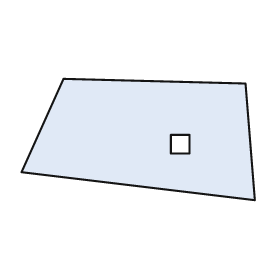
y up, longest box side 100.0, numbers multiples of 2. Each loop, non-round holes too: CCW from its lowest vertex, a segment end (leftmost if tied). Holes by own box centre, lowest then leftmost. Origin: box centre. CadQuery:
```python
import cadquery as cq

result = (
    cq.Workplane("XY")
    .moveTo(50.0, -26.0)
    .lineTo(46.0, 24.0)
    .lineTo(-32.0, 26.0)
    .lineTo(-50.0, -14.0)
    .close()
    .moveTo(14.0, -6.0)
    .lineTo(22.0, -6.0)
    .lineTo(22.0, 2.0)
    .lineTo(14.0, 2.0)
    .close()
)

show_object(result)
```